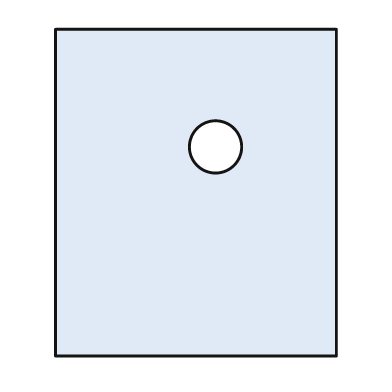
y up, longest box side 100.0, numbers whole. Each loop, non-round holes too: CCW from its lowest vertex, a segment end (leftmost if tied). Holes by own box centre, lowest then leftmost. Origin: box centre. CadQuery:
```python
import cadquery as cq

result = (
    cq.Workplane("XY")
    .moveTo(-43.0, -50.0)
    .lineTo(43.0, -50.0)
    .lineTo(43.0, 50.0)
    .lineTo(-43.0, 50.0)
    .close()
    .moveTo(6.0, 14.0)
    .circle(8.0)
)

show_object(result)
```